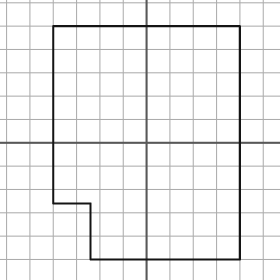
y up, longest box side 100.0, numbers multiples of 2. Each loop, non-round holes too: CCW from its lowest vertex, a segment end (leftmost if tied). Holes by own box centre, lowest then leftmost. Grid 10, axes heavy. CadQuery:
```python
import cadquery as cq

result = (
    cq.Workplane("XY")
    .moveTo(-24.0, -50.0)
    .lineTo(40.0, -50.0)
    .lineTo(40.0, 50.0)
    .lineTo(-40.0, 50.0)
    .lineTo(-40.0, -26.0)
    .lineTo(-24.0, -26.0)
    .close()
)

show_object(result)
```